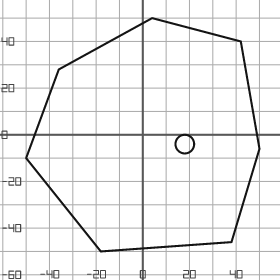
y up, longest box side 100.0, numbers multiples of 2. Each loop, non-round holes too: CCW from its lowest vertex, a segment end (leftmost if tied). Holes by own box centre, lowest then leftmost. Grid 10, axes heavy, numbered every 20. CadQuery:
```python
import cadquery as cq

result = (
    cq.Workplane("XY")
    .moveTo(-18.0, -50.0)
    .lineTo(38.0, -46.0)
    .lineTo(50.0, -6.0)
    .lineTo(42.0, 40.0)
    .lineTo(4.0, 50.0)
    .lineTo(-36.0, 28.0)
    .lineTo(-50.0, -10.0)
    .close()
    .moveTo(18.0, -4.0)
    .circle(4.0)
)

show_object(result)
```